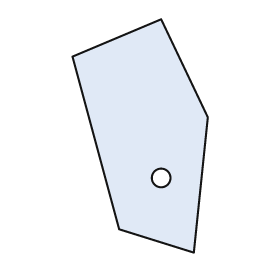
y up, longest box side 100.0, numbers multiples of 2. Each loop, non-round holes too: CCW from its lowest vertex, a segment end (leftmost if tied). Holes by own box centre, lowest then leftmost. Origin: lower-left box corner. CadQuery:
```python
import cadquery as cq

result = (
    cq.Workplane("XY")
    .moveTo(52.0, 0.0)
    .lineTo(58.0, 58.0)
    .lineTo(38.0, 100.0)
    .lineTo(0.0, 84.0)
    .lineTo(20.0, 10.0)
    .close()
    .moveTo(38.0, 32.0)
    .circle(4.0)
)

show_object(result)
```